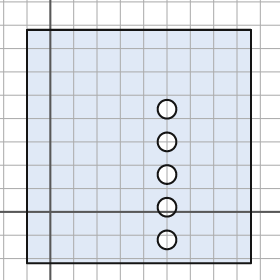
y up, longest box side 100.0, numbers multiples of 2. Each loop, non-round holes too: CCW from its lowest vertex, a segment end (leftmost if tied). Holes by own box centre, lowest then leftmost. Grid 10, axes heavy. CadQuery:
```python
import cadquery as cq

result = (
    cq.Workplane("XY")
    .moveTo(-10.0, -22.0)
    .lineTo(86.0, -22.0)
    .lineTo(86.0, 78.0)
    .lineTo(-10.0, 78.0)
    .close()
    .moveTo(50.0, -12.0)
    .circle(4.0)
    .moveTo(50.0, 2.0)
    .circle(4.0)
    .moveTo(50.0, 16.0)
    .circle(4.0)
    .moveTo(50.0, 30.0)
    .circle(4.0)
    .moveTo(50.0, 44.0)
    .circle(4.0)
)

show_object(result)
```